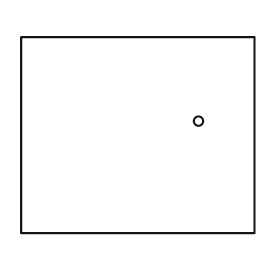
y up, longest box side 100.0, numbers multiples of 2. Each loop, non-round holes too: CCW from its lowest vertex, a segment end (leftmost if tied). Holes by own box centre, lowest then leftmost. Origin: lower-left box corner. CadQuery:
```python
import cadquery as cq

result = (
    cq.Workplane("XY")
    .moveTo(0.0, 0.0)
    .lineTo(100.0, 0.0)
    .lineTo(100.0, 84.0)
    .lineTo(0.0, 84.0)
    .close()
    .moveTo(76.0, 48.0)
    .circle(2.0)
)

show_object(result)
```